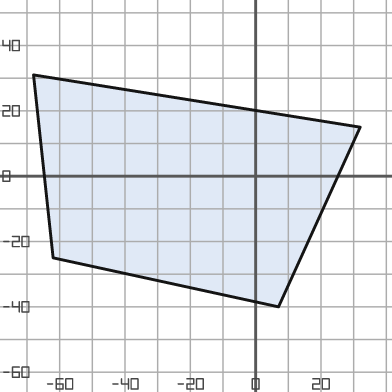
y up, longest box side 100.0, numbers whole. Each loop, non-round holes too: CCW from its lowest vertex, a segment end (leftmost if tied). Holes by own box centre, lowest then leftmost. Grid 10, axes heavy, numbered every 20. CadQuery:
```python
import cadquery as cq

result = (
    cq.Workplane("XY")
    .moveTo(7.0, -40.0)
    .lineTo(32.0, 15.0)
    .lineTo(-68.0, 31.0)
    .lineTo(-62.0, -25.0)
    .close()
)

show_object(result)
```